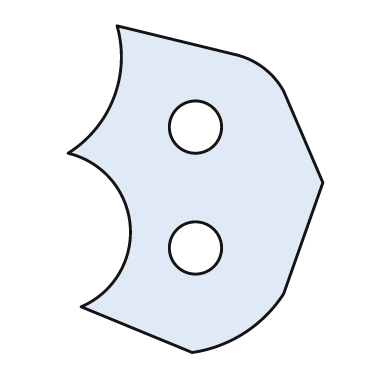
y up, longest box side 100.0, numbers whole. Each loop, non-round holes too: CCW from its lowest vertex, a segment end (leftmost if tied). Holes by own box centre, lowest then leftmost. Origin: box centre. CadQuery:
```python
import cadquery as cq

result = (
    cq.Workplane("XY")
    .moveTo(-1.0, -50.0)
    .threePointArc((15.0, -44.0), (27.0, -32.0))
    .lineTo(39.0, 2.0)
    .lineTo(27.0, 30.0)
    .threePointArc((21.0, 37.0), (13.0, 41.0))
    .lineTo(-24.0, 50.0)
    .threePointArc((-25.0, 28.0), (-39.0, 11.0))
    .threePointArc((-20.0, -11.0), (-35.0, -36.0))
    .close()
    .moveTo(0.0, -18.0)
    .circle(8.0)
    .moveTo(0.0, 19.0)
    .circle(8.0)
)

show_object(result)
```